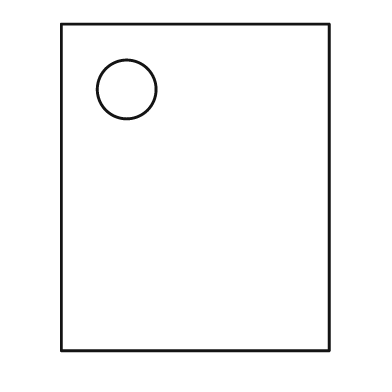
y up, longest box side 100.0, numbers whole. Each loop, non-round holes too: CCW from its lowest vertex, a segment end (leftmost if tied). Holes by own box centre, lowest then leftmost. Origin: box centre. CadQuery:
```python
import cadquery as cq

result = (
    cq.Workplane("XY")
    .moveTo(-41.0, -50.0)
    .lineTo(41.0, -50.0)
    .lineTo(41.0, 50.0)
    .lineTo(-41.0, 50.0)
    .close()
    .moveTo(-21.0, 30.0)
    .circle(9.0)
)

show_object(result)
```